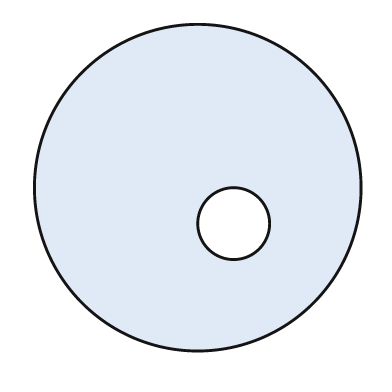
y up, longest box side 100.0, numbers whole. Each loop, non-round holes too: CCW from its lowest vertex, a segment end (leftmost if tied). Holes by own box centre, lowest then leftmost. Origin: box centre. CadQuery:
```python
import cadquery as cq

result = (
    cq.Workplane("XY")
    .moveTo(0.0, 0.0)
    .circle(50.0)
    .moveTo(11.0, -11.0)
    .circle(11.0)
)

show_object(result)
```